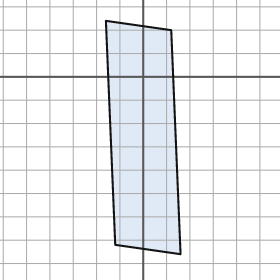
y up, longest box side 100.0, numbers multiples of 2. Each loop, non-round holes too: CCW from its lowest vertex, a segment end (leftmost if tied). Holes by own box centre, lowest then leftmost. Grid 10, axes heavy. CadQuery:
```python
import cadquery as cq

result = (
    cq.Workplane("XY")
    .moveTo(16.0, -76.0)
    .lineTo(12.0, 20.0)
    .lineTo(-16.0, 24.0)
    .lineTo(-12.0, -72.0)
    .close()
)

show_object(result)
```